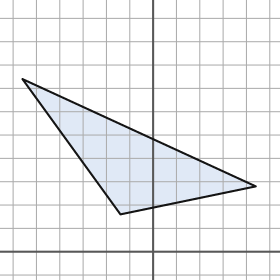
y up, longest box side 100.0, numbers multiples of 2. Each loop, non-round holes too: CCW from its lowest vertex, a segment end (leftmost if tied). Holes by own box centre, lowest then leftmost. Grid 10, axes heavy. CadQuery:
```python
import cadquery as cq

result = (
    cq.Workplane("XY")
    .moveTo(-14.0, 16.0)
    .lineTo(44.0, 28.0)
    .lineTo(-56.0, 74.0)
    .close()
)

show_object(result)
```